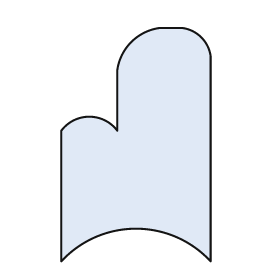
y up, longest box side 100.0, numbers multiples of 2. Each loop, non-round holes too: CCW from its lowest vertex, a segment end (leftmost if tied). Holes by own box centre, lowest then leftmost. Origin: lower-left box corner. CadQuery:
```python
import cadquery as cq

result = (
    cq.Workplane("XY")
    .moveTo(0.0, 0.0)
    .threePointArc((32.0, 14.0), (64.0, 0.0))
    .lineTo(64.0, 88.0)
    .threePointArc((60.0, 96.0), (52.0, 100.0))
    .lineTo(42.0, 100.0)
    .threePointArc((30.0, 94.0), (24.0, 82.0))
    .lineTo(24.0, 56.0)
    .threePointArc((12.0, 62.0), (0.0, 56.0))
    .close()
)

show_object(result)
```